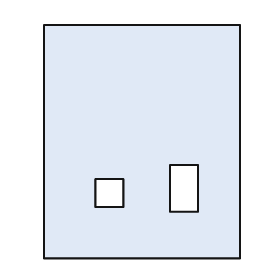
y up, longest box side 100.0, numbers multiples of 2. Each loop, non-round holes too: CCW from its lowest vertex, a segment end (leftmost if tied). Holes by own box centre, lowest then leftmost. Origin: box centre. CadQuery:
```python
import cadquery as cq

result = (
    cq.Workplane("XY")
    .moveTo(-42.0, -50.0)
    .lineTo(42.0, -50.0)
    .lineTo(42.0, 50.0)
    .lineTo(-42.0, 50.0)
    .close()
    .moveTo(-20.0, -28.0)
    .lineTo(-8.0, -28.0)
    .lineTo(-8.0, -16.0)
    .lineTo(-20.0, -16.0)
    .close()
    .moveTo(12.0, -30.0)
    .lineTo(24.0, -30.0)
    .lineTo(24.0, -10.0)
    .lineTo(12.0, -10.0)
    .close()
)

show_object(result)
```